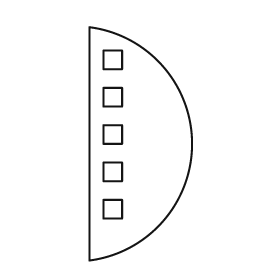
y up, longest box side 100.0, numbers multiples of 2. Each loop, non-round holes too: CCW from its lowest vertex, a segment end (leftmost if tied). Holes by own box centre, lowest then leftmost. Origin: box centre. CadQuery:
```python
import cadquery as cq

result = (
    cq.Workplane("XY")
    .moveTo(-22.0, -50.0)
    .threePointArc((22.0, 0.0), (-22.0, 50.0))
    .close()
    .moveTo(-16.0, -32.0)
    .lineTo(-8.0, -32.0)
    .lineTo(-8.0, -24.0)
    .lineTo(-16.0, -24.0)
    .close()
    .moveTo(-16.0, -16.0)
    .lineTo(-8.0, -16.0)
    .lineTo(-8.0, -8.0)
    .lineTo(-16.0, -8.0)
    .close()
    .moveTo(-16.0, 0.0)
    .lineTo(-8.0, 0.0)
    .lineTo(-8.0, 8.0)
    .lineTo(-16.0, 8.0)
    .close()
    .moveTo(-16.0, 16.0)
    .lineTo(-8.0, 16.0)
    .lineTo(-8.0, 24.0)
    .lineTo(-16.0, 24.0)
    .close()
    .moveTo(-16.0, 32.0)
    .lineTo(-8.0, 32.0)
    .lineTo(-8.0, 40.0)
    .lineTo(-16.0, 40.0)
    .close()
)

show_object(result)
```